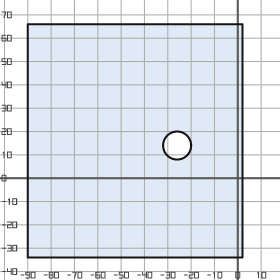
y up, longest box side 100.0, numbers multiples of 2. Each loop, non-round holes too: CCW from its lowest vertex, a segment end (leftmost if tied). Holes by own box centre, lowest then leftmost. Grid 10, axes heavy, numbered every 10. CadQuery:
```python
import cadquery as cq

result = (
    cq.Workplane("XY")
    .moveTo(-90.0, -34.0)
    .lineTo(2.0, -34.0)
    .lineTo(2.0, 66.0)
    .lineTo(-90.0, 66.0)
    .close()
    .moveTo(-26.0, 14.0)
    .circle(6.0)
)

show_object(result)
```